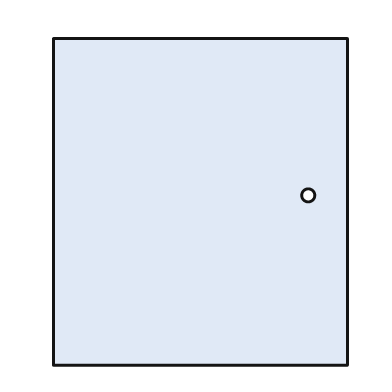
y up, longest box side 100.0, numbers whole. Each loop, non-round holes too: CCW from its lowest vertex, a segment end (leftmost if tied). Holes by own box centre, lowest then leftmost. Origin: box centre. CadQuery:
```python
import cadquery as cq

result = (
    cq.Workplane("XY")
    .moveTo(-45.0, -50.0)
    .lineTo(45.0, -50.0)
    .lineTo(45.0, 50.0)
    .lineTo(-45.0, 50.0)
    .close()
    .moveTo(33.0, 2.0)
    .circle(2.0)
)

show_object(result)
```